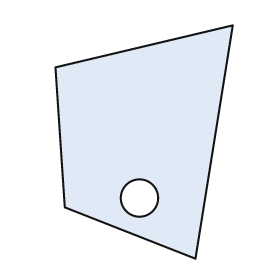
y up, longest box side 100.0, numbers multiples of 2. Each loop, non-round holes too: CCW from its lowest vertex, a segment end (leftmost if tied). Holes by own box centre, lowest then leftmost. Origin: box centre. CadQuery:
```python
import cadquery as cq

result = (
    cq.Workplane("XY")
    .moveTo(22.0, -50.0)
    .lineTo(38.0, 50.0)
    .lineTo(-38.0, 32.0)
    .lineTo(-34.0, -28.0)
    .close()
    .moveTo(-2.0, -24.0)
    .circle(8.0)
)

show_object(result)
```